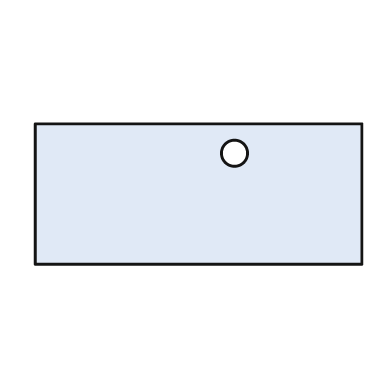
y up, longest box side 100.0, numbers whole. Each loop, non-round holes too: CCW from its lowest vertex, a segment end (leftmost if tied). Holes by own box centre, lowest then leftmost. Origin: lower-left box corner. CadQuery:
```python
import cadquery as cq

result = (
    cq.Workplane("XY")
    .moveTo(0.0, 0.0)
    .lineTo(100.0, 0.0)
    .lineTo(100.0, 43.0)
    .lineTo(0.0, 43.0)
    .close()
    .moveTo(61.0, 34.0)
    .circle(4.0)
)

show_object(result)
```